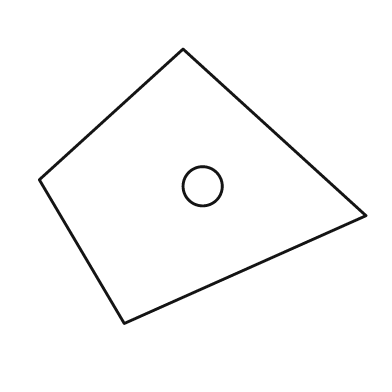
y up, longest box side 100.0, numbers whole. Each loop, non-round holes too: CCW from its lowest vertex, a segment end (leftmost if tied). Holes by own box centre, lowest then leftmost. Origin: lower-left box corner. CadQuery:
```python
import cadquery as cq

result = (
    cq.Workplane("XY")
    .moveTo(26.0, 0.0)
    .lineTo(100.0, 33.0)
    .lineTo(44.0, 84.0)
    .lineTo(0.0, 44.0)
    .close()
    .moveTo(50.0, 42.0)
    .circle(6.0)
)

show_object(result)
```